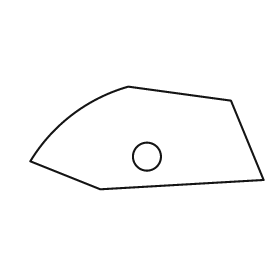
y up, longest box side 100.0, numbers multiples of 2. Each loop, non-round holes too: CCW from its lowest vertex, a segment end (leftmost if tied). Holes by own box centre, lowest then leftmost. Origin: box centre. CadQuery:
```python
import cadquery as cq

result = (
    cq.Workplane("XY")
    .moveTo(-20.0, -22.0)
    .lineTo(50.0, -18.0)
    .lineTo(36.0, 16.0)
    .lineTo(-8.0, 22.0)
    .threePointArc((-32.0, 10.0), (-50.0, -10.0))
    .close()
    .moveTo(0.0, -8.0)
    .circle(6.0)
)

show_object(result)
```